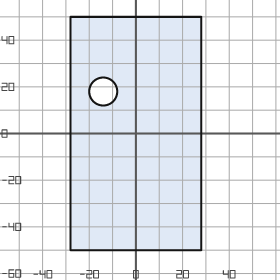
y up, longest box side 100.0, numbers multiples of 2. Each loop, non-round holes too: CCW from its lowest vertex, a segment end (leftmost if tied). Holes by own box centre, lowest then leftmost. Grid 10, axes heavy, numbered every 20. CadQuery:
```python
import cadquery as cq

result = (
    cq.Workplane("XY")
    .moveTo(-28.0, -50.0)
    .lineTo(28.0, -50.0)
    .lineTo(28.0, 50.0)
    .lineTo(-28.0, 50.0)
    .close()
    .moveTo(-14.0, 18.0)
    .circle(6.0)
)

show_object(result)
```